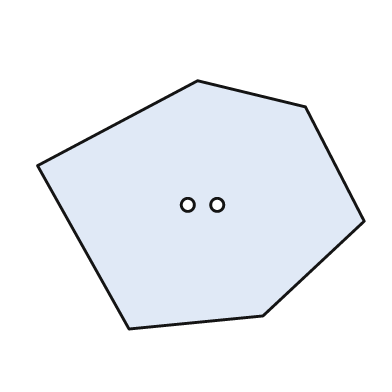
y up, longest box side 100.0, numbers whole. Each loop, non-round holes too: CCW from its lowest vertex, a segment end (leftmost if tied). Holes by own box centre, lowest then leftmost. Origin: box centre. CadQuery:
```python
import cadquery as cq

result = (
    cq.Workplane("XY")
    .moveTo(-22.0, -38.0)
    .lineTo(19.0, -34.0)
    .lineTo(50.0, -5.0)
    .lineTo(32.0, 30.0)
    .lineTo(-1.0, 38.0)
    .lineTo(-50.0, 12.0)
    .close()
    .moveTo(-4.0, 0.0)
    .circle(2.0)
    .moveTo(5.0, 0.0)
    .circle(2.0)
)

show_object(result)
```